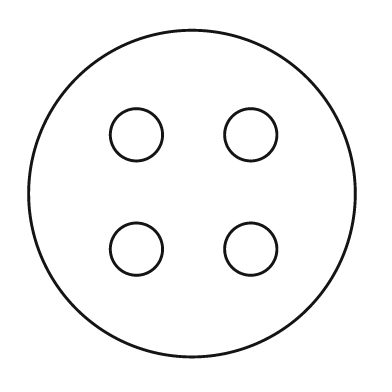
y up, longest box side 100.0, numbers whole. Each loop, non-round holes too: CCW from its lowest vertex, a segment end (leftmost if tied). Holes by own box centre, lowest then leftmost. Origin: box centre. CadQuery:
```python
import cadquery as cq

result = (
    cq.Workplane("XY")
    .moveTo(0.0, 0.0)
    .circle(50.0)
    .moveTo(-17.0, -17.0)
    .circle(8.0)
    .moveTo(18.0, -17.0)
    .circle(8.0)
    .moveTo(-17.0, 18.0)
    .circle(8.0)
    .moveTo(18.0, 18.0)
    .circle(8.0)
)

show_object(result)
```